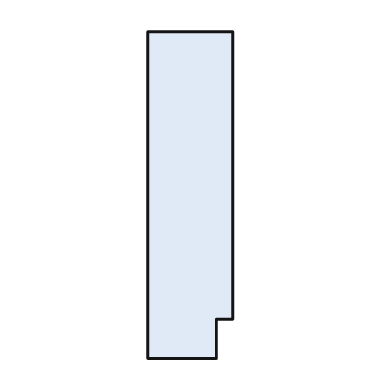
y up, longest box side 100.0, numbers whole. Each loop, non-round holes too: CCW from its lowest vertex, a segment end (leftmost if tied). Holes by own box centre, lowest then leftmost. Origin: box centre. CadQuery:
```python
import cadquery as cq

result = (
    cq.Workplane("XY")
    .moveTo(-13.0, -50.0)
    .lineTo(8.0, -50.0)
    .lineTo(8.0, -38.0)
    .lineTo(13.0, -38.0)
    .lineTo(13.0, 50.0)
    .lineTo(-13.0, 50.0)
    .close()
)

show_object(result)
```